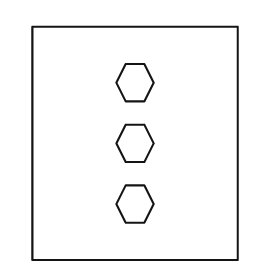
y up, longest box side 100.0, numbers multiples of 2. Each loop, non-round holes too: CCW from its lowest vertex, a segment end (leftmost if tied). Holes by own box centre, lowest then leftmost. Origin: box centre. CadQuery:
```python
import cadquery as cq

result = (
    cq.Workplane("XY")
    .moveTo(-44.0, -50.0)
    .lineTo(44.0, -50.0)
    .lineTo(44.0, 50.0)
    .lineTo(-44.0, 50.0)
    .close()
    .moveTo(-4.0, -34.0)
    .lineTo(4.0, -34.0)
    .lineTo(8.0, -26.0)
    .lineTo(4.0, -18.0)
    .lineTo(-4.0, -18.0)
    .lineTo(-8.0, -26.0)
    .close()
    .moveTo(-4.0, -8.0)
    .lineTo(4.0, -8.0)
    .lineTo(8.0, 0.0)
    .lineTo(4.0, 8.0)
    .lineTo(-4.0, 8.0)
    .lineTo(-8.0, 0.0)
    .close()
    .moveTo(-4.0, 18.0)
    .lineTo(4.0, 18.0)
    .lineTo(8.0, 26.0)
    .lineTo(4.0, 34.0)
    .lineTo(-4.0, 34.0)
    .lineTo(-8.0, 26.0)
    .close()
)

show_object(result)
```